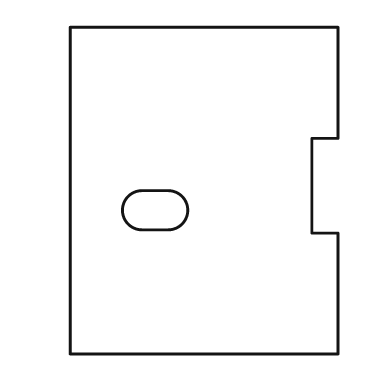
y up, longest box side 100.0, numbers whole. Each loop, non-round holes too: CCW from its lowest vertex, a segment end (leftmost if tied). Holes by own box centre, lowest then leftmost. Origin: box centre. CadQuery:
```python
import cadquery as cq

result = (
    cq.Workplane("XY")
    .moveTo(-41.0, -50.0)
    .lineTo(41.0, -50.0)
    .lineTo(41.0, -13.0)
    .lineTo(33.0, -13.0)
    .lineTo(33.0, 16.0)
    .lineTo(41.0, 16.0)
    .lineTo(41.0, 50.0)
    .lineTo(-41.0, 50.0)
    .close()
    .moveTo(-19.0, -12.0)
    .lineTo(-11.0, -12.0)
    .threePointArc((-5.0, -6.0), (-11.0, 0.0))
    .lineTo(-19.0, 0.0)
    .threePointArc((-25.0, -6.0), (-19.0, -12.0))
    .close()
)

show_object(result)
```